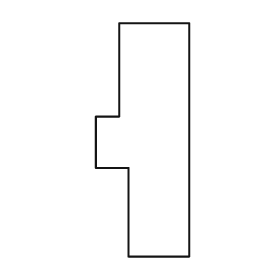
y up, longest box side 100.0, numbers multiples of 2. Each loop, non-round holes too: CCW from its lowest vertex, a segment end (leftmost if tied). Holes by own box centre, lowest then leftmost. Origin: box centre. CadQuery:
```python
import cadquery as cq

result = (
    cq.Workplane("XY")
    .moveTo(-6.0, -50.0)
    .lineTo(20.0, -50.0)
    .lineTo(20.0, 50.0)
    .lineTo(-10.0, 50.0)
    .lineTo(-10.0, 10.0)
    .lineTo(-20.0, 10.0)
    .lineTo(-20.0, -12.0)
    .lineTo(-6.0, -12.0)
    .close()
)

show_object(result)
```